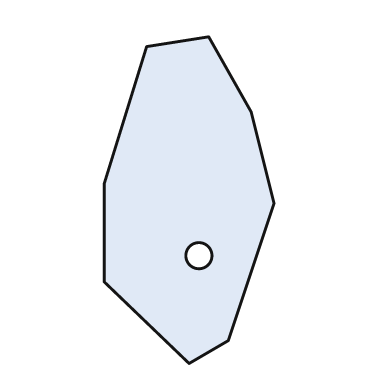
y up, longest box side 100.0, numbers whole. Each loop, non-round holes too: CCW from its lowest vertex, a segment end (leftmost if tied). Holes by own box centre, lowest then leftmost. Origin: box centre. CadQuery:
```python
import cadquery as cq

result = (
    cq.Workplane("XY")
    .moveTo(0.0, -50.0)
    .lineTo(12.0, -43.0)
    .lineTo(26.0, -1.0)
    .lineTo(19.0, 27.0)
    .lineTo(6.0, 50.0)
    .lineTo(-13.0, 47.0)
    .lineTo(-26.0, 5.0)
    .lineTo(-26.0, -25.0)
    .close()
    .moveTo(3.0, -17.0)
    .circle(4.0)
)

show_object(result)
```